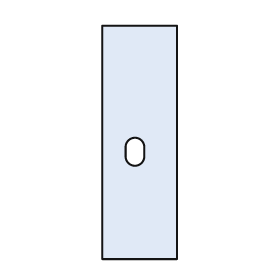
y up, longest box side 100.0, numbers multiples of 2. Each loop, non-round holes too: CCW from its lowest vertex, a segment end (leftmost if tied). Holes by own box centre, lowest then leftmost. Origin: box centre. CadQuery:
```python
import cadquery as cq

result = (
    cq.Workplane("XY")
    .moveTo(-16.0, -50.0)
    .lineTo(16.0, -50.0)
    .lineTo(16.0, 50.0)
    .lineTo(-16.0, 50.0)
    .close()
    .moveTo(-6.0, -6.0)
    .threePointArc((-2.0, -10.0), (2.0, -6.0))
    .lineTo(2.0, -2.0)
    .threePointArc((-2.0, 2.0), (-6.0, -2.0))
    .close()
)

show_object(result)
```